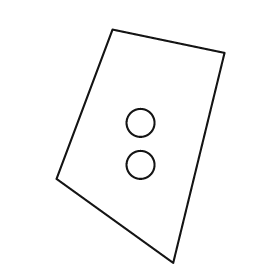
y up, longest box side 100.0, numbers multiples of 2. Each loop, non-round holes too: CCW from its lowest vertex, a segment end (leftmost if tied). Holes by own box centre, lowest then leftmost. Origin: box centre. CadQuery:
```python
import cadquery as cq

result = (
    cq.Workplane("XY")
    .moveTo(14.0, -50.0)
    .lineTo(36.0, 40.0)
    .lineTo(-12.0, 50.0)
    .lineTo(-36.0, -14.0)
    .close()
    .moveTo(0.0, -8.0)
    .circle(6.0)
    .moveTo(0.0, 10.0)
    .circle(6.0)
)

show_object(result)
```